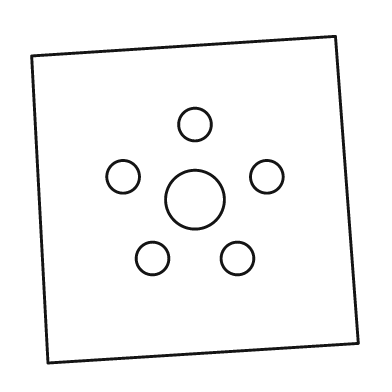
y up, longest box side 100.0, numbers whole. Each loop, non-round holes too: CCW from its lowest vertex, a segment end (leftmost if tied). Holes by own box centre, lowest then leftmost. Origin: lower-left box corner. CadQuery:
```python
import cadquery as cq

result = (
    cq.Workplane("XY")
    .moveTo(5.0, 0.0)
    .lineTo(100.0, 6.0)
    .lineTo(93.0, 100.0)
    .lineTo(0.0, 94.0)
    .close()
    .moveTo(37.0, 32.0)
    .circle(5.0)
    .moveTo(63.0, 32.0)
    .circle(5.0)
    .moveTo(50.0, 50.0)
    .circle(9.0)
    .moveTo(28.0, 57.0)
    .circle(5.0)
    .moveTo(72.0, 57.0)
    .circle(5.0)
    .moveTo(50.0, 73.0)
    .circle(5.0)
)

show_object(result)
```